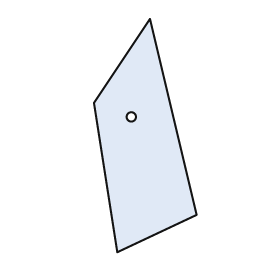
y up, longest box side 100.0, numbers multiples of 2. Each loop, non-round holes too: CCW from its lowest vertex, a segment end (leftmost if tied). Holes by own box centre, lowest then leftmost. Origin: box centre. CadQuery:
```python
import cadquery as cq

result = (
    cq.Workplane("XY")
    .moveTo(-12.0, -50.0)
    .lineTo(22.0, -34.0)
    .lineTo(2.0, 50.0)
    .lineTo(-22.0, 14.0)
    .close()
    .moveTo(-6.0, 8.0)
    .circle(2.0)
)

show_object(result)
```